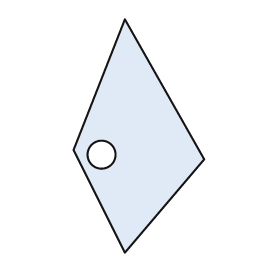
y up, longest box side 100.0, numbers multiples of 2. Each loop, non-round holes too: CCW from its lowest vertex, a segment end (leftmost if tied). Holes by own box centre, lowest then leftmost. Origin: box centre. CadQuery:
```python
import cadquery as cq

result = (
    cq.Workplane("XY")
    .moveTo(-6.0, -50.0)
    .lineTo(28.0, -10.0)
    .lineTo(-6.0, 50.0)
    .lineTo(-28.0, -6.0)
    .close()
    .moveTo(-16.0, -8.0)
    .circle(6.0)
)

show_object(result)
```